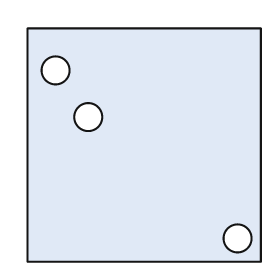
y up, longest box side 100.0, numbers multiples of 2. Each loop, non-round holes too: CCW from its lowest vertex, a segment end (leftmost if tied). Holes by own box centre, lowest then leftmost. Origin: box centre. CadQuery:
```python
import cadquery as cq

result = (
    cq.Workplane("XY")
    .moveTo(-50.0, -50.0)
    .lineTo(50.0, -50.0)
    .lineTo(50.0, 50.0)
    .lineTo(-50.0, 50.0)
    .close()
    .moveTo(40.0, -40.0)
    .circle(6.0)
    .moveTo(-24.0, 12.0)
    .circle(6.0)
    .moveTo(-38.0, 32.0)
    .circle(6.0)
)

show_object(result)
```